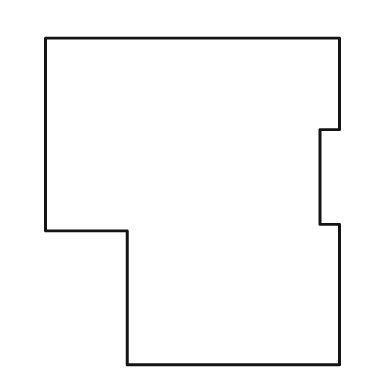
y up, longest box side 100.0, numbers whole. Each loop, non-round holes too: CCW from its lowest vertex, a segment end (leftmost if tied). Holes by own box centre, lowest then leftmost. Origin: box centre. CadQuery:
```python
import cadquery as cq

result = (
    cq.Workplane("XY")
    .moveTo(-20.0, -50.0)
    .lineTo(45.0, -50.0)
    .lineTo(45.0, -7.0)
    .lineTo(39.0, -7.0)
    .lineTo(39.0, 22.0)
    .lineTo(45.0, 22.0)
    .lineTo(45.0, 50.0)
    .lineTo(-45.0, 50.0)
    .lineTo(-45.0, -9.0)
    .lineTo(-20.0, -9.0)
    .close()
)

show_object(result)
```